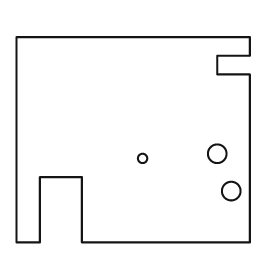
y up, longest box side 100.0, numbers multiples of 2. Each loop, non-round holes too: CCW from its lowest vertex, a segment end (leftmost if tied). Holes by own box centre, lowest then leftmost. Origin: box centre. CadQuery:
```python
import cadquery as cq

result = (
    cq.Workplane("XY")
    .moveTo(-50.0, -44.0)
    .lineTo(-40.0, -44.0)
    .lineTo(-40.0, -16.0)
    .lineTo(-22.0, -16.0)
    .lineTo(-22.0, -44.0)
    .lineTo(50.0, -44.0)
    .lineTo(50.0, 28.0)
    .lineTo(36.0, 28.0)
    .lineTo(36.0, 36.0)
    .lineTo(50.0, 36.0)
    .lineTo(50.0, 44.0)
    .lineTo(-50.0, 44.0)
    .close()
    .moveTo(42.0, -22.0)
    .circle(4.0)
    .moveTo(4.0, -8.0)
    .circle(2.0)
    .moveTo(36.0, -6.0)
    .circle(4.0)
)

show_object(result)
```